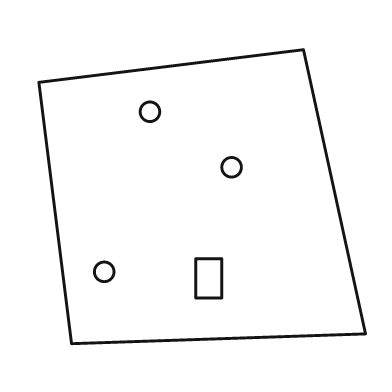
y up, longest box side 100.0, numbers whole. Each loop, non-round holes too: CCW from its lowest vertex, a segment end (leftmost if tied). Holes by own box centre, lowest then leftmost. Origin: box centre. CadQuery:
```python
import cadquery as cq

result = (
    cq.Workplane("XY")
    .moveTo(-40.0, -45.0)
    .lineTo(50.0, -42.0)
    .lineTo(31.0, 45.0)
    .lineTo(-50.0, 35.0)
    .close()
    .moveTo(-2.0, -31.0)
    .lineTo(6.0, -31.0)
    .lineTo(6.0, -19.0)
    .lineTo(-2.0, -19.0)
    .close()
    .moveTo(-30.0, -23.0)
    .circle(3.0)
    .moveTo(9.0, 9.0)
    .circle(3.0)
    .moveTo(-16.0, 26.0)
    .circle(3.0)
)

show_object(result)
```